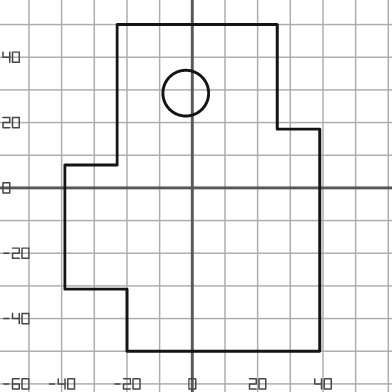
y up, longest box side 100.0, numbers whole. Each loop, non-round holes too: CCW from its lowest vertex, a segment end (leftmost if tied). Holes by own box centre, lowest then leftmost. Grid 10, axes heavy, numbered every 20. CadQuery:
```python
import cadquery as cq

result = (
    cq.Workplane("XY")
    .moveTo(-20.0, -50.0)
    .lineTo(39.0, -50.0)
    .lineTo(39.0, 18.0)
    .lineTo(26.0, 18.0)
    .lineTo(26.0, 50.0)
    .lineTo(-23.0, 50.0)
    .lineTo(-23.0, 7.0)
    .lineTo(-39.0, 7.0)
    .lineTo(-39.0, -31.0)
    .lineTo(-20.0, -31.0)
    .close()
    .moveTo(-2.0, 29.0)
    .circle(7.0)
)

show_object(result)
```